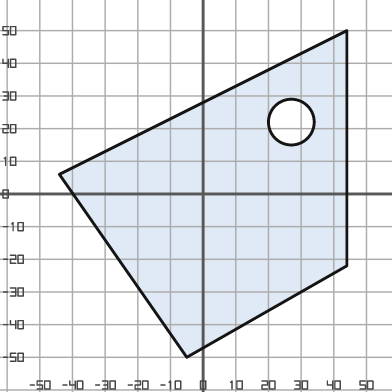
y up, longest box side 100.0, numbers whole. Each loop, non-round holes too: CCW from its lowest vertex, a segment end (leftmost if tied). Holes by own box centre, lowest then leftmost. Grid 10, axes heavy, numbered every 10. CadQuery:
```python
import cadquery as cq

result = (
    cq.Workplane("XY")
    .moveTo(-5.0, -50.0)
    .lineTo(44.0, -22.0)
    .lineTo(44.0, 50.0)
    .lineTo(-44.0, 6.0)
    .close()
    .moveTo(27.0, 22.0)
    .circle(7.0)
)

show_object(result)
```